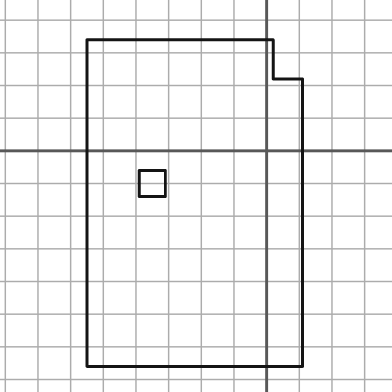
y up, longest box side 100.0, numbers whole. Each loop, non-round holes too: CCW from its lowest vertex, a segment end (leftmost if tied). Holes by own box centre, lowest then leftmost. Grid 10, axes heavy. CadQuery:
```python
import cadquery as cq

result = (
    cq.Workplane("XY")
    .moveTo(-55.0, -66.0)
    .lineTo(11.0, -66.0)
    .lineTo(11.0, 22.0)
    .lineTo(2.0, 22.0)
    .lineTo(2.0, 34.0)
    .lineTo(-55.0, 34.0)
    .close()
    .moveTo(-39.0, -14.0)
    .lineTo(-31.0, -14.0)
    .lineTo(-31.0, -6.0)
    .lineTo(-39.0, -6.0)
    .close()
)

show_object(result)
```